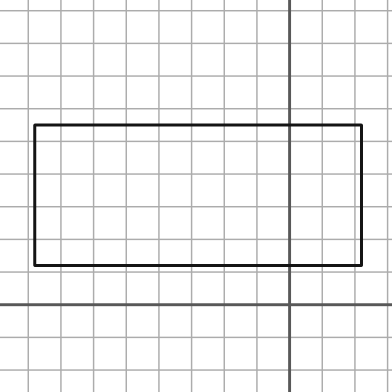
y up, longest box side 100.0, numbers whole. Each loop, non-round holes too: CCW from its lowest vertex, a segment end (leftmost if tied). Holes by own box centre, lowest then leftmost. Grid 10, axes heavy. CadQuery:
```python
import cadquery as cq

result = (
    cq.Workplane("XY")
    .moveTo(-78.0, 12.0)
    .lineTo(22.0, 12.0)
    .lineTo(22.0, 55.0)
    .lineTo(-78.0, 55.0)
    .close()
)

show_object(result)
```